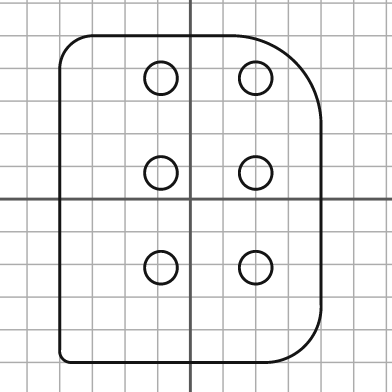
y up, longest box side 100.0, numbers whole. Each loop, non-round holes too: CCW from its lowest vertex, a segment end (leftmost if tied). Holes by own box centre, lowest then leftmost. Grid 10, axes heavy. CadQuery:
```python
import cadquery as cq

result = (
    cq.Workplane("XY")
    .moveTo(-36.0, -50.0)
    .lineTo(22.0, -50.0)
    .threePointArc((35.0, -45.0), (40.0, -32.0))
    .lineTo(40.0, 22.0)
    .threePointArc((32.0, 42.0), (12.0, 50.0))
    .lineTo(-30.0, 50.0)
    .threePointArc((-37.0, 47.0), (-40.0, 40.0))
    .lineTo(-40.0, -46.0)
    .threePointArc((-39.0, -49.0), (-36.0, -50.0))
    .close()
    .moveTo(-9.0, -21.0)
    .circle(5.0)
    .moveTo(20.0, -21.0)
    .circle(5.0)
    .moveTo(-9.0, 8.0)
    .circle(5.0)
    .moveTo(20.0, 8.0)
    .circle(5.0)
    .moveTo(-9.0, 37.0)
    .circle(5.0)
    .moveTo(20.0, 37.0)
    .circle(5.0)
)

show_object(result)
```